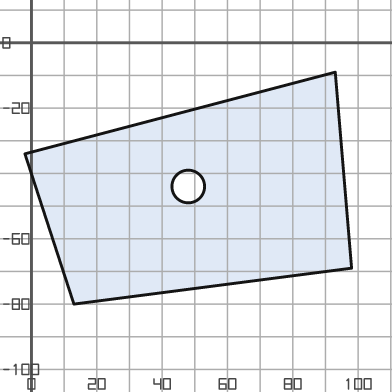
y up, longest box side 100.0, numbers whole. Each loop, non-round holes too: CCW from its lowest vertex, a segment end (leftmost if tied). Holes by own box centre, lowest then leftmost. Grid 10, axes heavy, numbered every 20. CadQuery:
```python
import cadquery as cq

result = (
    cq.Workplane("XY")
    .moveTo(13.0, -80.0)
    .lineTo(98.0, -69.0)
    .lineTo(93.0, -9.0)
    .lineTo(-2.0, -34.0)
    .close()
    .moveTo(48.0, -44.0)
    .circle(5.0)
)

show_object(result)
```